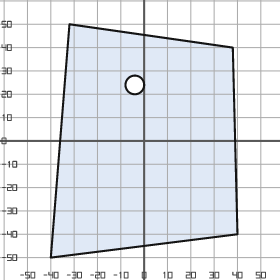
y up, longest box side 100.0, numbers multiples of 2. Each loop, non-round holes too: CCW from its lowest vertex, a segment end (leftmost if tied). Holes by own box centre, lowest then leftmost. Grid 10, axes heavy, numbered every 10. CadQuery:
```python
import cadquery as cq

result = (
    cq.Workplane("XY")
    .moveTo(-40.0, -50.0)
    .lineTo(40.0, -40.0)
    .lineTo(38.0, 40.0)
    .lineTo(-32.0, 50.0)
    .close()
    .moveTo(-4.0, 24.0)
    .circle(4.0)
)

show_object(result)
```